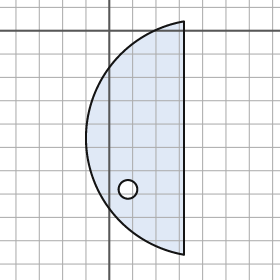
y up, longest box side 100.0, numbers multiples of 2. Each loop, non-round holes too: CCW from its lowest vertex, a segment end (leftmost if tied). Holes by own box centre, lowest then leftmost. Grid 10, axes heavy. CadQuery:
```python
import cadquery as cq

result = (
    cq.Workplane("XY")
    .moveTo(32.0, -96.0)
    .lineTo(32.0, 4.0)
    .threePointArc((-10.0, -46.0), (32.0, -96.0))
    .close()
    .moveTo(8.0, -68.0)
    .circle(4.0)
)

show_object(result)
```